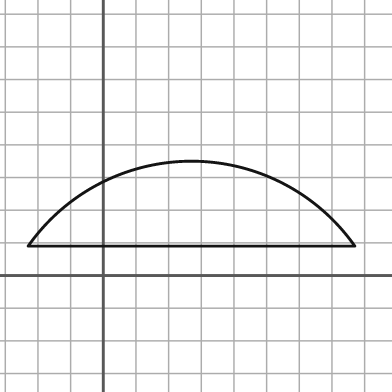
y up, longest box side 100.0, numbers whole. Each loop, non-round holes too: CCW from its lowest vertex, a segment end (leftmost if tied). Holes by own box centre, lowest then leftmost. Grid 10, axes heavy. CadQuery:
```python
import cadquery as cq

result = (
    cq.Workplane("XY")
    .moveTo(-23.0, 9.0)
    .lineTo(77.0, 9.0)
    .threePointArc((27.0, 35.0), (-23.0, 9.0))
    .close()
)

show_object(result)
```